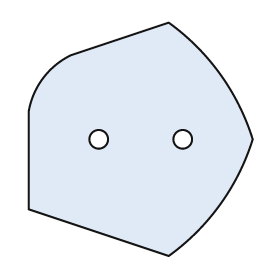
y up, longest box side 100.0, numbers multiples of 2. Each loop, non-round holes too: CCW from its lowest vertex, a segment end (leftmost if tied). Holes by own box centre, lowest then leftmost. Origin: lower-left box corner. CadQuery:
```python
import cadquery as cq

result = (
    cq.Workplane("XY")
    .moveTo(60.0, 0.0)
    .threePointArc((82.0, 22.0), (96.0, 50.0))
    .threePointArc((82.0, 78.0), (60.0, 100.0))
    .lineTo(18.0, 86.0)
    .threePointArc((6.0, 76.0), (0.0, 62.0))
    .lineTo(0.0, 20.0)
    .close()
    .moveTo(30.0, 50.0)
    .circle(4.0)
    .moveTo(66.0, 50.0)
    .circle(4.0)
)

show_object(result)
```